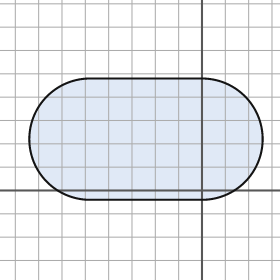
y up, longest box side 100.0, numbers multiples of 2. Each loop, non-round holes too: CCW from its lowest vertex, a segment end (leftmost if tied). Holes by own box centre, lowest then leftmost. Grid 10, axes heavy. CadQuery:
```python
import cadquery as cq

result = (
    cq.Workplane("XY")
    .moveTo(-48.0, -4.0)
    .lineTo(0.0, -4.0)
    .threePointArc((26.0, 22.0), (0.0, 48.0))
    .lineTo(-48.0, 48.0)
    .threePointArc((-74.0, 22.0), (-48.0, -4.0))
    .close()
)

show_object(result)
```